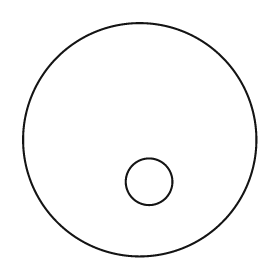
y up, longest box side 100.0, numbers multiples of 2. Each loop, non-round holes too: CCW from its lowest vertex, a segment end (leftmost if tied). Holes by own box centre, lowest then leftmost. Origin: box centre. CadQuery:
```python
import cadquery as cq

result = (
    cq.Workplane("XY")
    .moveTo(0.0, 0.0)
    .circle(50.0)
    .moveTo(4.0, -18.0)
    .circle(10.0)
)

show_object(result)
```